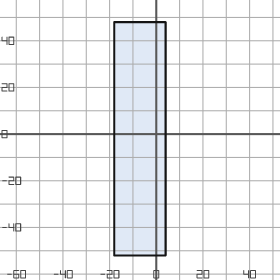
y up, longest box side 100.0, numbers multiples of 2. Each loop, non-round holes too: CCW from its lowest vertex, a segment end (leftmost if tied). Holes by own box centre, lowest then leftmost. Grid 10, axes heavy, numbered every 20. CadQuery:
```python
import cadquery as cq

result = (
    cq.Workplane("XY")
    .moveTo(-18.0, -52.0)
    .lineTo(4.0, -52.0)
    .lineTo(4.0, 48.0)
    .lineTo(-18.0, 48.0)
    .close()
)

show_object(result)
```